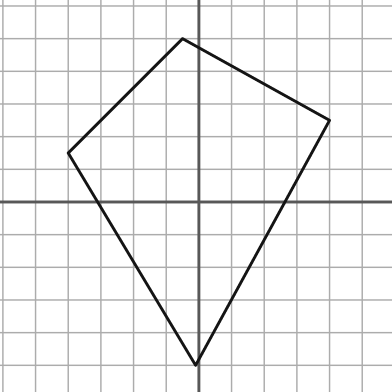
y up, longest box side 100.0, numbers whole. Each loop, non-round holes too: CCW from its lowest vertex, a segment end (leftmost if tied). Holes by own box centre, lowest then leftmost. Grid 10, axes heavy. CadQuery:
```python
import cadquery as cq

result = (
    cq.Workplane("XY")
    .moveTo(-1.0, -50.0)
    .lineTo(40.0, 25.0)
    .lineTo(-5.0, 50.0)
    .lineTo(-40.0, 15.0)
    .close()
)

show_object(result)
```